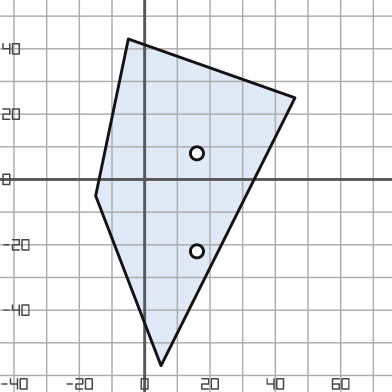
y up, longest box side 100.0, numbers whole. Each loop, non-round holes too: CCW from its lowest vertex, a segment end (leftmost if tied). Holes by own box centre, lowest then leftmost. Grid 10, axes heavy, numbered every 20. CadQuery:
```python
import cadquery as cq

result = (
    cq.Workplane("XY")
    .moveTo(5.0, -57.0)
    .lineTo(46.0, 25.0)
    .lineTo(-5.0, 43.0)
    .lineTo(-15.0, -5.0)
    .close()
    .moveTo(16.0, -22.0)
    .circle(2.0)
    .moveTo(16.0, 8.0)
    .circle(2.0)
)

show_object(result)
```